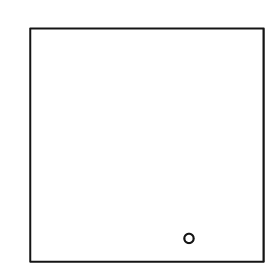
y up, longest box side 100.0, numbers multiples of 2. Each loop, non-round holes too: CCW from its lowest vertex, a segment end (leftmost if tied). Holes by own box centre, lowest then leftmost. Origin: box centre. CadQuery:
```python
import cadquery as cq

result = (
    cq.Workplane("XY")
    .moveTo(-50.0, -50.0)
    .lineTo(50.0, -50.0)
    .lineTo(50.0, 50.0)
    .lineTo(-50.0, 50.0)
    .close()
    .moveTo(18.0, -40.0)
    .circle(2.0)
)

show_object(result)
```